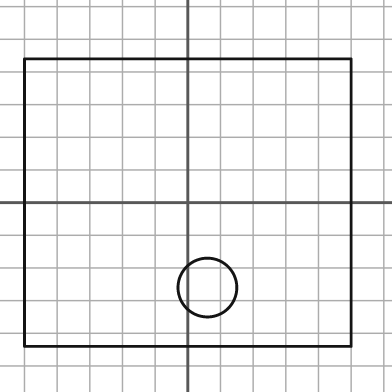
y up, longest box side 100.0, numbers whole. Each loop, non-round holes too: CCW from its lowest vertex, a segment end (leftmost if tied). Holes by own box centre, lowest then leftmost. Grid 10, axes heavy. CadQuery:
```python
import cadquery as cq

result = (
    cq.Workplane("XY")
    .moveTo(-50.0, -44.0)
    .lineTo(50.0, -44.0)
    .lineTo(50.0, 44.0)
    .lineTo(-50.0, 44.0)
    .close()
    .moveTo(6.0, -26.0)
    .circle(9.0)
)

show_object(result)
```